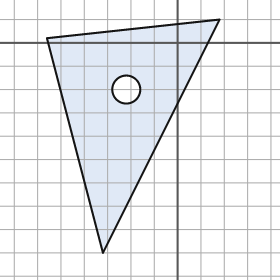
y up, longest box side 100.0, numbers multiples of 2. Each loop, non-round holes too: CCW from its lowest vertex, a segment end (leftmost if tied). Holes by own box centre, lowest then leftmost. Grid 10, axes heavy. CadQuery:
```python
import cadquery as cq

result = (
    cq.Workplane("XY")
    .moveTo(-32.0, -90.0)
    .lineTo(18.0, 10.0)
    .lineTo(-56.0, 2.0)
    .close()
    .moveTo(-22.0, -20.0)
    .circle(6.0)
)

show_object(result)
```